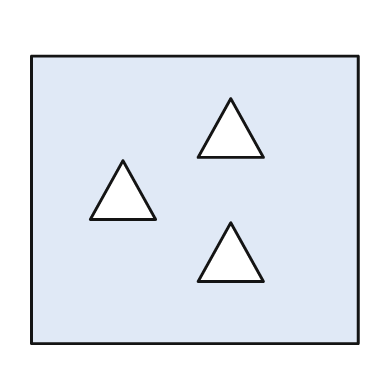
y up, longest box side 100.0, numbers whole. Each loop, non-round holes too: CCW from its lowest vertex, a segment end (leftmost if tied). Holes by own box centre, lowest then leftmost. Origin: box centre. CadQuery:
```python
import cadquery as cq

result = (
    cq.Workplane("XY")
    .moveTo(-50.0, -44.0)
    .lineTo(50.0, -44.0)
    .lineTo(50.0, 44.0)
    .lineTo(-50.0, 44.0)
    .close()
    .moveTo(1.0, -25.0)
    .lineTo(21.0, -25.0)
    .lineTo(11.0, -7.0)
    .close()
    .moveTo(-32.0, -6.0)
    .lineTo(-12.0, -6.0)
    .lineTo(-22.0, 12.0)
    .close()
    .moveTo(1.0, 13.0)
    .lineTo(21.0, 13.0)
    .lineTo(11.0, 31.0)
    .close()
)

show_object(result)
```